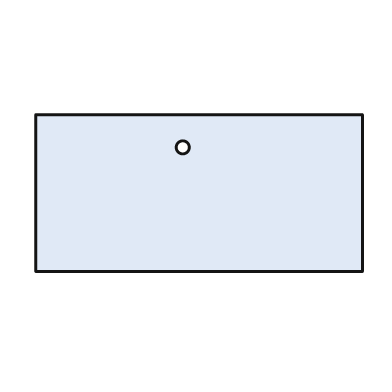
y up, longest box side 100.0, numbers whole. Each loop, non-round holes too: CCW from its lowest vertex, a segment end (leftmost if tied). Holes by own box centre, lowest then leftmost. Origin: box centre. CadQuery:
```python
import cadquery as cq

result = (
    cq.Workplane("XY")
    .moveTo(-50.0, -24.0)
    .lineTo(50.0, -24.0)
    .lineTo(50.0, 24.0)
    .lineTo(-50.0, 24.0)
    .close()
    .moveTo(-5.0, 14.0)
    .circle(2.0)
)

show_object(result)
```